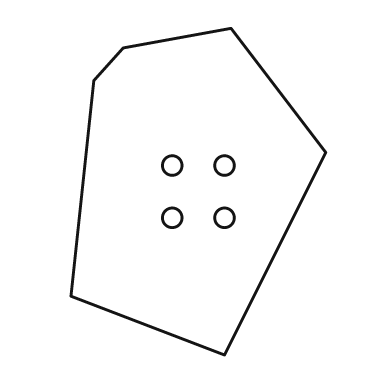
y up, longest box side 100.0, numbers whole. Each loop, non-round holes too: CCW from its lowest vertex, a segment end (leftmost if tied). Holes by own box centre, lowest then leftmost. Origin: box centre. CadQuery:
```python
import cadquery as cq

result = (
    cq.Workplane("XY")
    .moveTo(8.0, -50.0)
    .lineTo(39.0, 12.0)
    .lineTo(10.0, 50.0)
    .lineTo(-23.0, 44.0)
    .lineTo(-32.0, 34.0)
    .lineTo(-39.0, -32.0)
    .close()
    .moveTo(-8.0, -8.0)
    .circle(3.0)
    .moveTo(8.0, -8.0)
    .circle(3.0)
    .moveTo(-8.0, 8.0)
    .circle(3.0)
    .moveTo(8.0, 8.0)
    .circle(3.0)
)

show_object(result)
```